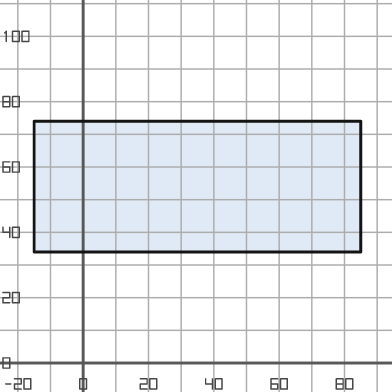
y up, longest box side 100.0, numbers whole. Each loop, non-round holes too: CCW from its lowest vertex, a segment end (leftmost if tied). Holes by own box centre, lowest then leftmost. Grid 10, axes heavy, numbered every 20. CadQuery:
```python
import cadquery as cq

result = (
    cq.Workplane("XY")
    .moveTo(-15.0, 34.0)
    .lineTo(85.0, 34.0)
    .lineTo(85.0, 74.0)
    .lineTo(-15.0, 74.0)
    .close()
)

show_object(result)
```